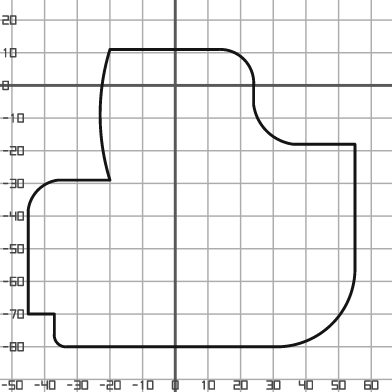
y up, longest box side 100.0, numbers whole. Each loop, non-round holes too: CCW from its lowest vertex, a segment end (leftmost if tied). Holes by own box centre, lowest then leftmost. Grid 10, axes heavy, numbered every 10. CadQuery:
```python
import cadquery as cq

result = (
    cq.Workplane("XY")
    .moveTo(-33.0, -80.0)
    .lineTo(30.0, -80.0)
    .threePointArc((48.0, -73.0), (55.0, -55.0))
    .lineTo(55.0, -18.0)
    .lineTo(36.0, -18.0)
    .threePointArc((28.0, -14.0), (24.0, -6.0))
    .lineTo(24.0, 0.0)
    .threePointArc((21.0, 8.0), (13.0, 11.0))
    .lineTo(-20.0, 11.0)
    .threePointArc((-23.0, -9.0), (-20.0, -29.0))
    .lineTo(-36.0, -29.0)
    .threePointArc((-42.0, -32.0), (-45.0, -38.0))
    .lineTo(-45.0, -70.0)
    .lineTo(-37.0, -70.0)
    .lineTo(-37.0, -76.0)
    .threePointArc((-36.0, -79.0), (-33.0, -80.0))
    .close()
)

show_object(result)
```